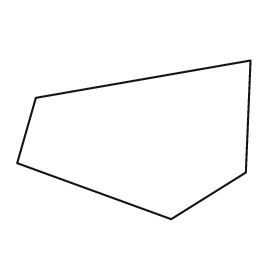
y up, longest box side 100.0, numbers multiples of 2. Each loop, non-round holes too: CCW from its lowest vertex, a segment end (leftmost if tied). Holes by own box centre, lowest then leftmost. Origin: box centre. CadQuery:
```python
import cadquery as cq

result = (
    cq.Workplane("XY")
    .moveTo(16.0, -34.0)
    .lineTo(48.0, -14.0)
    .lineTo(50.0, 34.0)
    .lineTo(-42.0, 18.0)
    .lineTo(-50.0, -10.0)
    .close()
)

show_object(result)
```